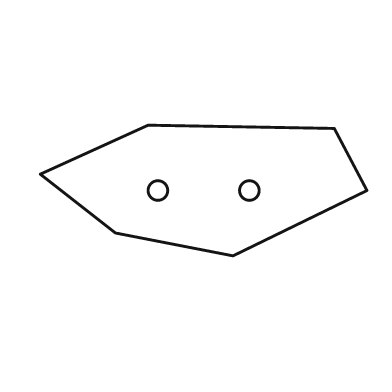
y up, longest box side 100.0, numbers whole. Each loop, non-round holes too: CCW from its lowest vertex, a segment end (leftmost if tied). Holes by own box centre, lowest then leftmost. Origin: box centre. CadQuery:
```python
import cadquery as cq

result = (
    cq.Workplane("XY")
    .moveTo(9.0, -20.0)
    .lineTo(50.0, 0.0)
    .lineTo(40.0, 19.0)
    .lineTo(-17.0, 20.0)
    .lineTo(-50.0, 5.0)
    .lineTo(-27.0, -13.0)
    .close()
    .moveTo(-14.0, 0.0)
    .circle(3.0)
    .moveTo(14.0, 0.0)
    .circle(3.0)
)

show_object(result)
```